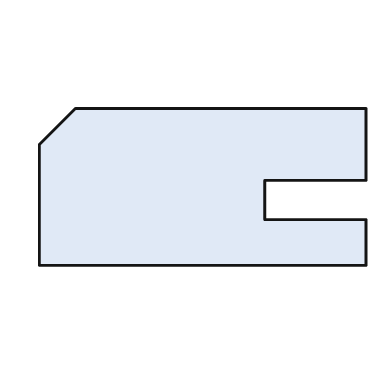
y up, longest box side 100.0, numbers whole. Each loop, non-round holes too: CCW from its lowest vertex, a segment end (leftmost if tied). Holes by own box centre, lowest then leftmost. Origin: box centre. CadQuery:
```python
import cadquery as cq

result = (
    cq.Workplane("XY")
    .moveTo(-50.0, -24.0)
    .lineTo(50.0, -24.0)
    .lineTo(50.0, -10.0)
    .lineTo(19.0, -10.0)
    .lineTo(19.0, 2.0)
    .lineTo(50.0, 2.0)
    .lineTo(50.0, 24.0)
    .lineTo(-39.0, 24.0)
    .lineTo(-50.0, 13.0)
    .close()
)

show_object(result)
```